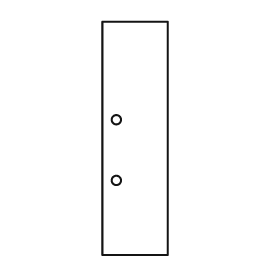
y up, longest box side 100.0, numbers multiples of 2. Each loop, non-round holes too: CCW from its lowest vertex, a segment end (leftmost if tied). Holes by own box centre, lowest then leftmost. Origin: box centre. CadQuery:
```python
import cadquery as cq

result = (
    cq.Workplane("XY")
    .moveTo(-14.0, -50.0)
    .lineTo(14.0, -50.0)
    .lineTo(14.0, 50.0)
    .lineTo(-14.0, 50.0)
    .close()
    .moveTo(-8.0, -18.0)
    .circle(2.0)
    .moveTo(-8.0, 8.0)
    .circle(2.0)
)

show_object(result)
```